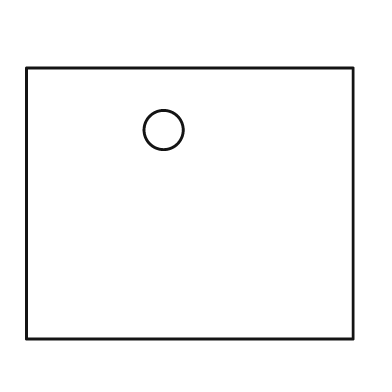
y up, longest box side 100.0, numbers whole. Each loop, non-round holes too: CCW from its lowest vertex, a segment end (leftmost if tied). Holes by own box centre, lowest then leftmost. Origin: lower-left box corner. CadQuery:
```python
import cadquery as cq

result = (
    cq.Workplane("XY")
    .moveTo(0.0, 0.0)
    .lineTo(100.0, 0.0)
    .lineTo(100.0, 83.0)
    .lineTo(0.0, 83.0)
    .close()
    .moveTo(42.0, 64.0)
    .circle(6.0)
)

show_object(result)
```